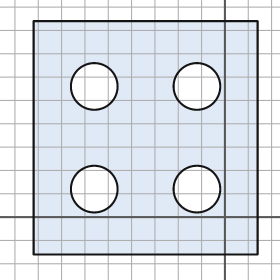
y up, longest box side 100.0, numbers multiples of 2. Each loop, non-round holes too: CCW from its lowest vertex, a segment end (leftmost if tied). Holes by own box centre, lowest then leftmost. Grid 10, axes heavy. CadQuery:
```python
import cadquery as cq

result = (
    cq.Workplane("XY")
    .moveTo(-82.0, -16.0)
    .lineTo(14.0, -16.0)
    .lineTo(14.0, 84.0)
    .lineTo(-82.0, 84.0)
    .close()
    .moveTo(-56.0, 12.0)
    .circle(10.0)
    .moveTo(-12.0, 12.0)
    .circle(10.0)
    .moveTo(-56.0, 56.0)
    .circle(10.0)
    .moveTo(-12.0, 56.0)
    .circle(10.0)
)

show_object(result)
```